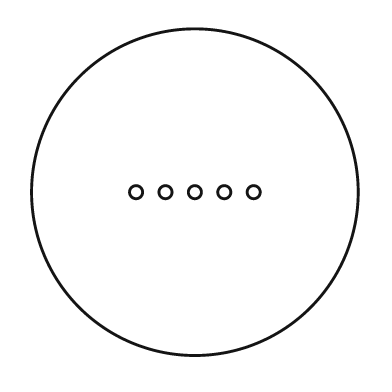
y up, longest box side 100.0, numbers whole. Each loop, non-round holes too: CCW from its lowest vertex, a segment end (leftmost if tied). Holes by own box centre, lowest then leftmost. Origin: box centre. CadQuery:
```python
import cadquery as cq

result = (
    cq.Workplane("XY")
    .moveTo(0.0, 0.0)
    .circle(50.0)
    .moveTo(-18.0, 0.0)
    .circle(2.0)
    .moveTo(-9.0, 0.0)
    .circle(2.0)
    .moveTo(0.0, 0.0)
    .circle(2.0)
    .moveTo(9.0, 0.0)
    .circle(2.0)
    .moveTo(18.0, 0.0)
    .circle(2.0)
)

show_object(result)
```